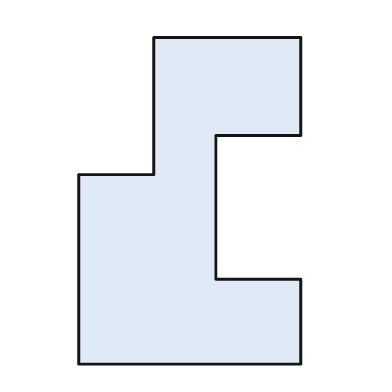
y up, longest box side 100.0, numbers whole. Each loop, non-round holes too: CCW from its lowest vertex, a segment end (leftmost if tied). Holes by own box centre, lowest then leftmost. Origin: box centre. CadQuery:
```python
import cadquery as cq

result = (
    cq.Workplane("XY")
    .moveTo(-34.0, -50.0)
    .lineTo(34.0, -50.0)
    .lineTo(34.0, -24.0)
    .lineTo(8.0, -24.0)
    .lineTo(8.0, 20.0)
    .lineTo(34.0, 20.0)
    .lineTo(34.0, 50.0)
    .lineTo(-11.0, 50.0)
    .lineTo(-11.0, 8.0)
    .lineTo(-34.0, 8.0)
    .close()
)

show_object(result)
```